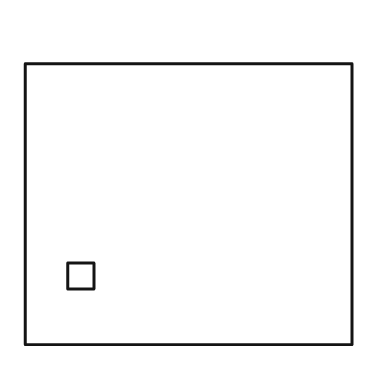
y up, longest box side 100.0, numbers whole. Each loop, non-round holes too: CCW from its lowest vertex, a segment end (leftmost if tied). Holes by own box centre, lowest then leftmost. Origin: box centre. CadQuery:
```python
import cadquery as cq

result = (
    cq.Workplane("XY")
    .moveTo(-50.0, -43.0)
    .lineTo(50.0, -43.0)
    .lineTo(50.0, 43.0)
    .lineTo(-50.0, 43.0)
    .close()
    .moveTo(-37.0, -26.0)
    .lineTo(-29.0, -26.0)
    .lineTo(-29.0, -18.0)
    .lineTo(-37.0, -18.0)
    .close()
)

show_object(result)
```